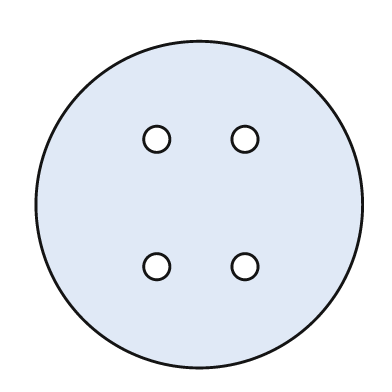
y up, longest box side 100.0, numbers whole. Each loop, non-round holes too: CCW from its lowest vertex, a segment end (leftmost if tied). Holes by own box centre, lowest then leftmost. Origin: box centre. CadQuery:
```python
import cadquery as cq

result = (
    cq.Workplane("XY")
    .moveTo(0.0, 0.0)
    .circle(50.0)
    .moveTo(-13.0, -19.0)
    .circle(4.0)
    .moveTo(14.0, -19.0)
    .circle(4.0)
    .moveTo(-13.0, 20.0)
    .circle(4.0)
    .moveTo(14.0, 20.0)
    .circle(4.0)
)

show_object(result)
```